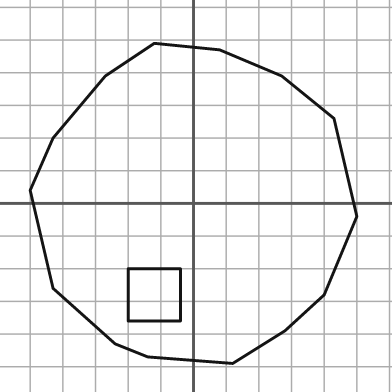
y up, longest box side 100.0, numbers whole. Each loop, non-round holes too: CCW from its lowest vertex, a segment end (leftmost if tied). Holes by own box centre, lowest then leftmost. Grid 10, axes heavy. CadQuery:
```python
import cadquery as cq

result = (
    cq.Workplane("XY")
    .moveTo(12.0, -49.0)
    .lineTo(28.0, -39.0)
    .lineTo(40.0, -28.0)
    .lineTo(50.0, -4.0)
    .lineTo(43.0, 26.0)
    .lineTo(27.0, 39.0)
    .lineTo(8.0, 47.0)
    .lineTo(-12.0, 49.0)
    .lineTo(-27.0, 39.0)
    .lineTo(-43.0, 20.0)
    .lineTo(-50.0, 4.0)
    .lineTo(-43.0, -26.0)
    .lineTo(-24.0, -43.0)
    .lineTo(-14.0, -47.0)
    .close()
    .moveTo(-20.0, -36.0)
    .lineTo(-4.0, -36.0)
    .lineTo(-4.0, -20.0)
    .lineTo(-20.0, -20.0)
    .close()
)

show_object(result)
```